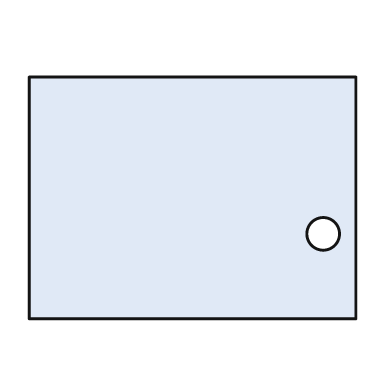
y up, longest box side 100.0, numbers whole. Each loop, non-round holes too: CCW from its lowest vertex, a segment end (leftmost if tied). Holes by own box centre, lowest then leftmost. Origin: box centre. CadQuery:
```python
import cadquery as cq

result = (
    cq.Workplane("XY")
    .moveTo(-50.0, -37.0)
    .lineTo(50.0, -37.0)
    .lineTo(50.0, 37.0)
    .lineTo(-50.0, 37.0)
    .close()
    .moveTo(40.0, -11.0)
    .circle(5.0)
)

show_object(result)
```